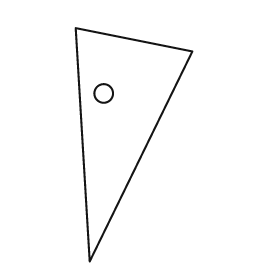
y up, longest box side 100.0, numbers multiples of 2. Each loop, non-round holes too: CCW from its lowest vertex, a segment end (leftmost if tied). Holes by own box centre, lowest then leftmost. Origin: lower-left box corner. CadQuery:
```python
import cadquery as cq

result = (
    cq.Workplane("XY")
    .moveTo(6.0, 0.0)
    .lineTo(50.0, 90.0)
    .lineTo(0.0, 100.0)
    .close()
    .moveTo(12.0, 72.0)
    .circle(4.0)
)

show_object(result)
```